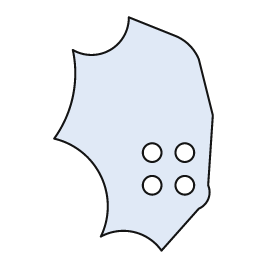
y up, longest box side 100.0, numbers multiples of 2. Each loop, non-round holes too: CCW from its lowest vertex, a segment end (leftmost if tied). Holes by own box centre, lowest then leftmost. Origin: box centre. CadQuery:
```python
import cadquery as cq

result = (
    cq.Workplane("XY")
    .moveTo(12.0, -50.0)
    .lineTo(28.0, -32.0)
    .threePointArc((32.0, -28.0), (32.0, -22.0))
    .lineTo(34.0, 8.0)
    .lineTo(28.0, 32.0)
    .threePointArc((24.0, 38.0), (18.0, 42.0))
    .lineTo(-2.0, 50.0)
    .threePointArc((-10.0, 36.0), (-26.0, 36.0))
    .threePointArc((-26.0, 16.0), (-34.0, -2.0))
    .threePointArc((-14.0, -18.0), (-14.0, -44.0))
    .threePointArc((0.0, -42.0), (12.0, -50.0))
    .close()
    .moveTo(8.0, -22.0)
    .circle(4.0)
    .moveTo(22.0, -22.0)
    .circle(4.0)
    .moveTo(8.0, -8.0)
    .circle(4.0)
    .moveTo(22.0, -8.0)
    .circle(4.0)
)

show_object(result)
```